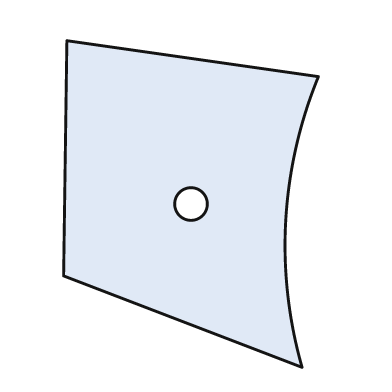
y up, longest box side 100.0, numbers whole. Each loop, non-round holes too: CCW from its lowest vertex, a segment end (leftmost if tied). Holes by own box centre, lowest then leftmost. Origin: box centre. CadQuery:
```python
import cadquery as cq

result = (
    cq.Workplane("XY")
    .moveTo(34.0, -50.0)
    .threePointArc((29.0, -5.0), (39.0, 39.0))
    .lineTo(-38.0, 50.0)
    .lineTo(-39.0, -22.0)
    .close()
    .moveTo(0.0, 0.0)
    .circle(5.0)
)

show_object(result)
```